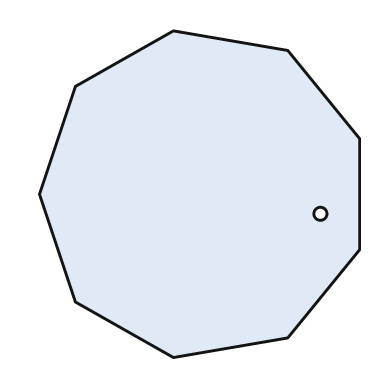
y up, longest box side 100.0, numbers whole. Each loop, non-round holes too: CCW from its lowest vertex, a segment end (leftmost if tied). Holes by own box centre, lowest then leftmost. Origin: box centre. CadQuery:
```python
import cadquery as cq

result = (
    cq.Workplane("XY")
    .moveTo(-8.0, -50.0)
    .lineTo(27.0, -44.0)
    .lineTo(49.0, -17.0)
    .lineTo(49.0, 17.0)
    .lineTo(27.0, 44.0)
    .lineTo(-8.0, 50.0)
    .lineTo(-38.0, 33.0)
    .lineTo(-49.0, 0.0)
    .lineTo(-38.0, -33.0)
    .close()
    .moveTo(37.0, -6.0)
    .circle(2.0)
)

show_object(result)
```